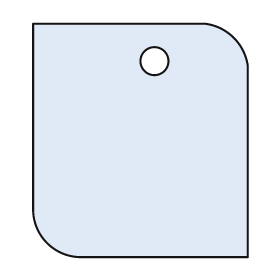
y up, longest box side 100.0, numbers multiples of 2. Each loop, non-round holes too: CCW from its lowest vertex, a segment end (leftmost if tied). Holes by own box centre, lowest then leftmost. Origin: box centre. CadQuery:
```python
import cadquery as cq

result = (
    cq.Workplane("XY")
    .moveTo(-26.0, -50.0)
    .lineTo(46.0, -50.0)
    .lineTo(46.0, 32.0)
    .threePointArc((40.0, 44.0), (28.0, 50.0))
    .lineTo(-46.0, 50.0)
    .lineTo(-46.0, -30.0)
    .threePointArc((-40.0, -44.0), (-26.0, -50.0))
    .close()
    .moveTo(6.0, 34.0)
    .circle(6.0)
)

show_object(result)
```